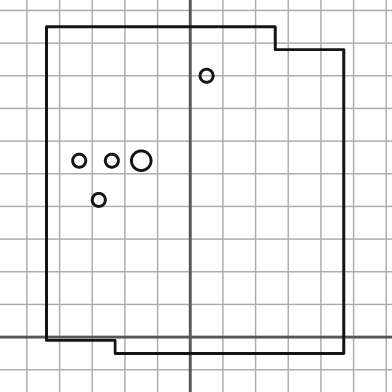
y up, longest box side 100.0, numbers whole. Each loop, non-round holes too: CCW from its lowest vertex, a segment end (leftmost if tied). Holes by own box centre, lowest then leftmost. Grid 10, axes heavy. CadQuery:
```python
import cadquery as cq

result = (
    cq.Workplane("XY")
    .moveTo(-23.0, -5.0)
    .lineTo(47.0, -5.0)
    .lineTo(47.0, 88.0)
    .lineTo(26.0, 88.0)
    .lineTo(26.0, 95.0)
    .lineTo(-44.0, 95.0)
    .lineTo(-44.0, -1.0)
    .lineTo(-23.0, -1.0)
    .close()
    .moveTo(-28.0, 42.0)
    .circle(2.0)
    .moveTo(-34.0, 54.0)
    .circle(2.0)
    .moveTo(-24.0, 54.0)
    .circle(2.0)
    .moveTo(-15.0, 54.0)
    .circle(3.0)
    .moveTo(5.0, 80.0)
    .circle(2.0)
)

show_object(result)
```